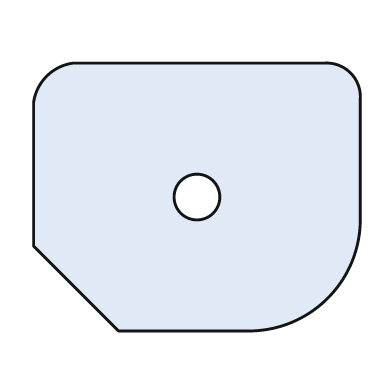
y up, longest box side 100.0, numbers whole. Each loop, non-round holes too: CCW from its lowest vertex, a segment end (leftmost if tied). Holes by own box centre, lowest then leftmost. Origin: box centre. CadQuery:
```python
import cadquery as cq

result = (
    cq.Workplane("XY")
    .moveTo(-24.0, -41.0)
    .lineTo(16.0, -41.0)
    .threePointArc((40.0, -31.0), (50.0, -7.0))
    .lineTo(50.0, 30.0)
    .threePointArc((47.0, 38.0), (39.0, 41.0))
    .lineTo(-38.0, 41.0)
    .threePointArc((-46.0, 37.0), (-50.0, 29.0))
    .lineTo(-50.0, -15.0)
    .close()
    .moveTo(0.0, 0.0)
    .circle(7.0)
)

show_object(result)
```